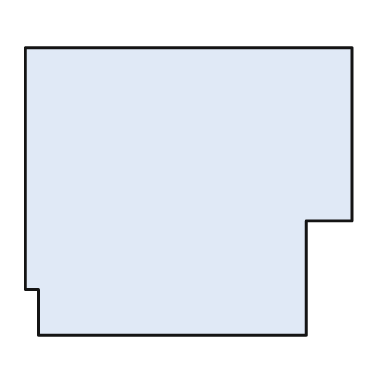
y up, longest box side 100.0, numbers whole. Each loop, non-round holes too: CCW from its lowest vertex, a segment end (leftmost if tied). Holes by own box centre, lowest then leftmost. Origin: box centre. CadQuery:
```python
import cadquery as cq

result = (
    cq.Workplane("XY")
    .moveTo(-46.0, -44.0)
    .lineTo(36.0, -44.0)
    .lineTo(36.0, -9.0)
    .lineTo(50.0, -9.0)
    .lineTo(50.0, 44.0)
    .lineTo(-50.0, 44.0)
    .lineTo(-50.0, -30.0)
    .lineTo(-46.0, -30.0)
    .close()
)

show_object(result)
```